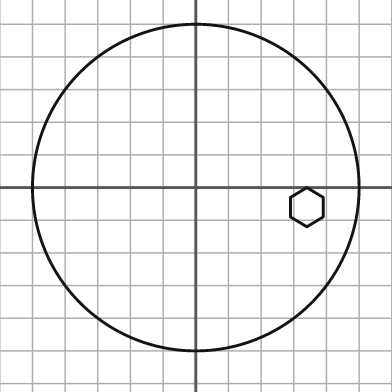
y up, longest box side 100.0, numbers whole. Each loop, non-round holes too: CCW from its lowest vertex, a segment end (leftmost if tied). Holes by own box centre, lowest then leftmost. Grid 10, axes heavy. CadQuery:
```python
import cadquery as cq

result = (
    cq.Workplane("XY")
    .moveTo(0.0, 0.0)
    .circle(50.0)
    .moveTo(34.0, -12.0)
    .lineTo(39.0, -9.0)
    .lineTo(39.0, -3.0)
    .lineTo(34.0, 0.0)
    .lineTo(29.0, -3.0)
    .lineTo(29.0, -9.0)
    .close()
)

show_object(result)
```